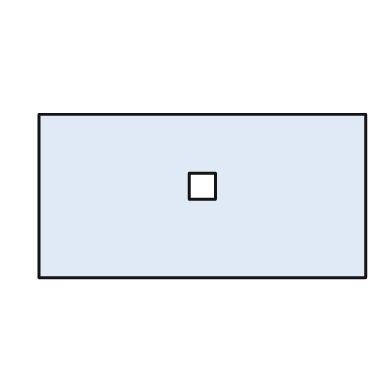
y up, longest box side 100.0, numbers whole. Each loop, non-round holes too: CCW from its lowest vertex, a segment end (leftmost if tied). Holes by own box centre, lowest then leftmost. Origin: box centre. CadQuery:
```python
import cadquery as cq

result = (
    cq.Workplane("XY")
    .moveTo(-50.0, -25.0)
    .lineTo(50.0, -25.0)
    .lineTo(50.0, 25.0)
    .lineTo(-50.0, 25.0)
    .close()
    .moveTo(-4.0, -1.0)
    .lineTo(4.0, -1.0)
    .lineTo(4.0, 7.0)
    .lineTo(-4.0, 7.0)
    .close()
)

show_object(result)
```